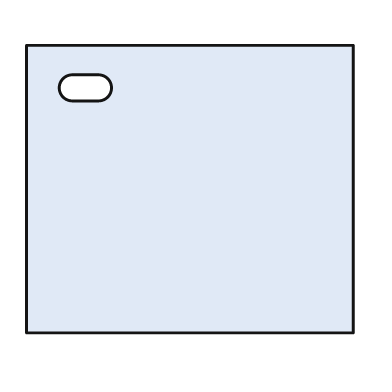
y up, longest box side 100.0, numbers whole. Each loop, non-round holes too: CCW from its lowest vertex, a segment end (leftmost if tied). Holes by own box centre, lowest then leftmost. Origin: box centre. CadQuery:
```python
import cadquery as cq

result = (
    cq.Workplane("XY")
    .moveTo(-50.0, -44.0)
    .lineTo(50.0, -44.0)
    .lineTo(50.0, 44.0)
    .lineTo(-50.0, 44.0)
    .close()
    .moveTo(-36.0, 27.0)
    .lineTo(-28.0, 27.0)
    .threePointArc((-24.0, 31.0), (-28.0, 35.0))
    .lineTo(-36.0, 35.0)
    .threePointArc((-40.0, 31.0), (-36.0, 27.0))
    .close()
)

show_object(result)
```